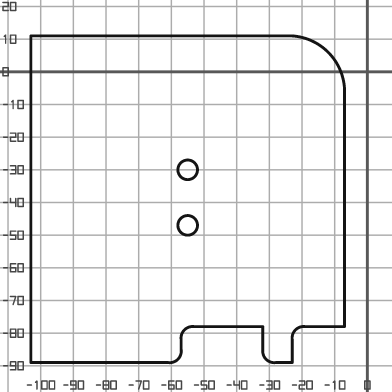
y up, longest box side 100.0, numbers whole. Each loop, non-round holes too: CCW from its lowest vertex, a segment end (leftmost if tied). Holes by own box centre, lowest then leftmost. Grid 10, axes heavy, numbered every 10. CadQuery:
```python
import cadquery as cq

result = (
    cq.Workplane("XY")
    .moveTo(-103.0, -89.0)
    .lineTo(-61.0, -89.0)
    .threePointArc((-58.0, -88.0), (-57.0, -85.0))
    .lineTo(-57.0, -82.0)
    .threePointArc((-56.0, -79.0), (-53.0, -78.0))
    .lineTo(-32.0, -78.0)
    .lineTo(-32.0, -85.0)
    .threePointArc((-31.0, -88.0), (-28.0, -89.0))
    .lineTo(-23.0, -89.0)
    .lineTo(-23.0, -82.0)
    .threePointArc((-22.0, -79.0), (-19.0, -78.0))
    .lineTo(-7.0, -78.0)
    .lineTo(-7.0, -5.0)
    .threePointArc((-12.0, 6.0), (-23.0, 11.0))
    .lineTo(-103.0, 11.0)
    .close()
    .moveTo(-55.0, -47.0)
    .circle(3.0)
    .moveTo(-55.0, -30.0)
    .circle(3.0)
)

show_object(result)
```